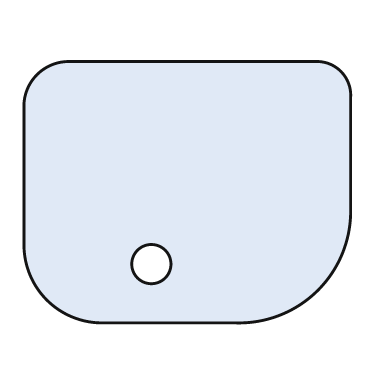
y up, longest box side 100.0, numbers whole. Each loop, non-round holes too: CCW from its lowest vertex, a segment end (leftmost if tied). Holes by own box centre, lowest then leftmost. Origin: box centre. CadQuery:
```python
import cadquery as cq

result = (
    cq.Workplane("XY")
    .moveTo(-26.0, -40.0)
    .lineTo(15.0, -40.0)
    .threePointArc((40.0, -30.0), (50.0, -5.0))
    .lineTo(50.0, 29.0)
    .threePointArc((47.0, 37.0), (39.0, 40.0))
    .lineTo(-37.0, 40.0)
    .threePointArc((-46.0, 36.0), (-50.0, 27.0))
    .lineTo(-50.0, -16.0)
    .threePointArc((-43.0, -33.0), (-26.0, -40.0))
    .close()
    .moveTo(-11.0, -22.0)
    .circle(6.0)
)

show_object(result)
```